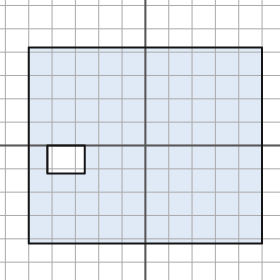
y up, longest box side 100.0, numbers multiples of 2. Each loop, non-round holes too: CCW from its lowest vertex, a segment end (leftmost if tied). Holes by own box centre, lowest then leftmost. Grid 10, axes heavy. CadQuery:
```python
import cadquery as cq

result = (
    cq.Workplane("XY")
    .moveTo(-50.0, -42.0)
    .lineTo(50.0, -42.0)
    .lineTo(50.0, 42.0)
    .lineTo(-50.0, 42.0)
    .close()
    .moveTo(-42.0, -12.0)
    .lineTo(-26.0, -12.0)
    .lineTo(-26.0, 0.0)
    .lineTo(-42.0, 0.0)
    .close()
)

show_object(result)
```